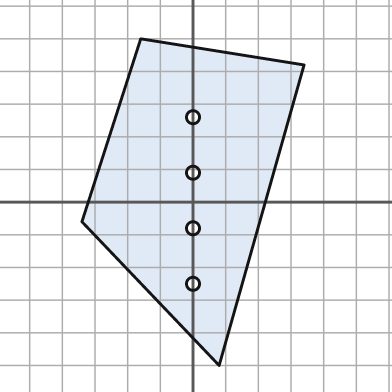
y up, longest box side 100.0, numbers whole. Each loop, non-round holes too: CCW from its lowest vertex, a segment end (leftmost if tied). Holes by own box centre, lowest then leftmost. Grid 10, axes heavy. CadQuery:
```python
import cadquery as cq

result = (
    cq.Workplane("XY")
    .moveTo(8.0, -50.0)
    .lineTo(34.0, 42.0)
    .lineTo(-16.0, 50.0)
    .lineTo(-34.0, -6.0)
    .close()
    .moveTo(0.0, -25.0)
    .circle(2.0)
    .moveTo(0.0, -8.0)
    .circle(2.0)
    .moveTo(0.0, 9.0)
    .circle(2.0)
    .moveTo(0.0, 26.0)
    .circle(2.0)
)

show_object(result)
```